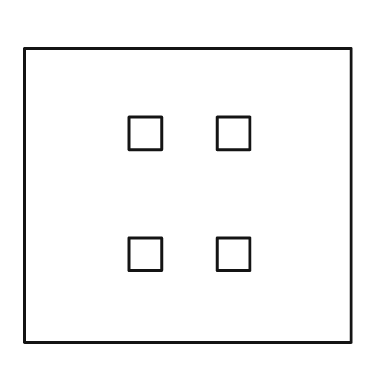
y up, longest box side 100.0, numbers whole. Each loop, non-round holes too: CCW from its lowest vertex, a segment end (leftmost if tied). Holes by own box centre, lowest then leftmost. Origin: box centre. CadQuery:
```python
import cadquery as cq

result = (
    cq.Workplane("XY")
    .moveTo(-50.0, -45.0)
    .lineTo(50.0, -45.0)
    .lineTo(50.0, 45.0)
    .lineTo(-50.0, 45.0)
    .close()
    .moveTo(-18.0, -23.0)
    .lineTo(-8.0, -23.0)
    .lineTo(-8.0, -13.0)
    .lineTo(-18.0, -13.0)
    .close()
    .moveTo(9.0, -23.0)
    .lineTo(19.0, -23.0)
    .lineTo(19.0, -13.0)
    .lineTo(9.0, -13.0)
    .close()
    .moveTo(-18.0, 14.0)
    .lineTo(-8.0, 14.0)
    .lineTo(-8.0, 24.0)
    .lineTo(-18.0, 24.0)
    .close()
    .moveTo(9.0, 14.0)
    .lineTo(19.0, 14.0)
    .lineTo(19.0, 24.0)
    .lineTo(9.0, 24.0)
    .close()
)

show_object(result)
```